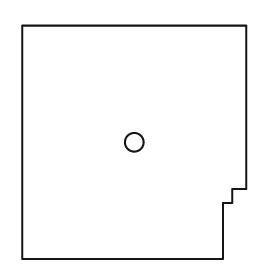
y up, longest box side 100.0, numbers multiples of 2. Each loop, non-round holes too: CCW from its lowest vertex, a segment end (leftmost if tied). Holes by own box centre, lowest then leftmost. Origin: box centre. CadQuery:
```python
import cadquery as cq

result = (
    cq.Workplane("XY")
    .moveTo(-48.0, -50.0)
    .lineTo(38.0, -50.0)
    .lineTo(38.0, -26.0)
    .lineTo(42.0, -26.0)
    .lineTo(42.0, -20.0)
    .lineTo(48.0, -20.0)
    .lineTo(48.0, 50.0)
    .lineTo(-48.0, 50.0)
    .close()
    .moveTo(0.0, 0.0)
    .circle(4.0)
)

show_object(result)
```